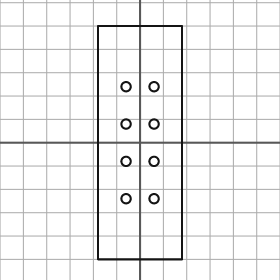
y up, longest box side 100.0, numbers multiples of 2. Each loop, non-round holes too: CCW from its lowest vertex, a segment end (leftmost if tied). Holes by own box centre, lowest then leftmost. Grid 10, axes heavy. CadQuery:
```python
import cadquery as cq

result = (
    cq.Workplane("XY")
    .moveTo(-18.0, -50.0)
    .lineTo(18.0, -50.0)
    .lineTo(18.0, 50.0)
    .lineTo(-18.0, 50.0)
    .close()
    .moveTo(-6.0, -24.0)
    .circle(2.0)
    .moveTo(6.0, -24.0)
    .circle(2.0)
    .moveTo(-6.0, -8.0)
    .circle(2.0)
    .moveTo(6.0, -8.0)
    .circle(2.0)
    .moveTo(-6.0, 8.0)
    .circle(2.0)
    .moveTo(6.0, 8.0)
    .circle(2.0)
    .moveTo(-6.0, 24.0)
    .circle(2.0)
    .moveTo(6.0, 24.0)
    .circle(2.0)
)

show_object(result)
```